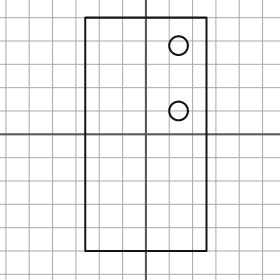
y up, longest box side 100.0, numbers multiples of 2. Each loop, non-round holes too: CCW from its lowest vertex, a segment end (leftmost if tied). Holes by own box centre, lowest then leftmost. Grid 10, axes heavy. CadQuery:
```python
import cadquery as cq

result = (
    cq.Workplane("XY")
    .moveTo(-26.0, -50.0)
    .lineTo(26.0, -50.0)
    .lineTo(26.0, 50.0)
    .lineTo(-26.0, 50.0)
    .close()
    .moveTo(14.0, 10.0)
    .circle(4.0)
    .moveTo(14.0, 38.0)
    .circle(4.0)
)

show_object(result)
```